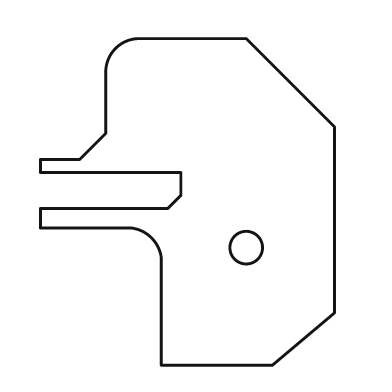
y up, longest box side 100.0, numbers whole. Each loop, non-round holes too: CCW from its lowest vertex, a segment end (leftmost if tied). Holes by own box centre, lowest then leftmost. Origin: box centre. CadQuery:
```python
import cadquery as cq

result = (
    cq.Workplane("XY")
    .moveTo(-8.0, -50.0)
    .lineTo(26.0, -50.0)
    .lineTo(45.0, -34.0)
    .lineTo(45.0, 23.0)
    .lineTo(18.0, 50.0)
    .lineTo(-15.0, 50.0)
    .threePointArc((-22.0, 47.0), (-25.0, 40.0))
    .lineTo(-25.0, 21.0)
    .lineTo(-33.0, 13.0)
    .lineTo(-45.0, 13.0)
    .lineTo(-45.0, 9.0)
    .lineTo(-2.0, 9.0)
    .lineTo(-2.0, 2.0)
    .lineTo(-6.0, -2.0)
    .lineTo(-45.0, -2.0)
    .lineTo(-45.0, -8.0)
    .lineTo(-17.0, -8.0)
    .threePointArc((-11.0, -11.0), (-8.0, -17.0))
    .close()
    .moveTo(18.0, -14.0)
    .circle(5.0)
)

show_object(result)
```